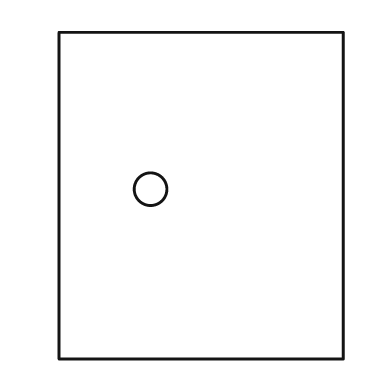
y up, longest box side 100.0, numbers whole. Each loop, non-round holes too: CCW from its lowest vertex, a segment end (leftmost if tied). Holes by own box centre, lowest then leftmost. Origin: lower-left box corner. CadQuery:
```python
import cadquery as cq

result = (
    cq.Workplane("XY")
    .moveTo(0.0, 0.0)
    .lineTo(87.0, 0.0)
    .lineTo(87.0, 100.0)
    .lineTo(0.0, 100.0)
    .close()
    .moveTo(28.0, 52.0)
    .circle(5.0)
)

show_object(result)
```